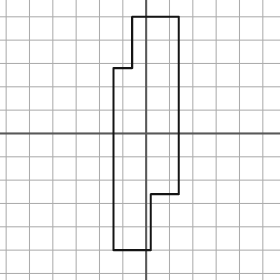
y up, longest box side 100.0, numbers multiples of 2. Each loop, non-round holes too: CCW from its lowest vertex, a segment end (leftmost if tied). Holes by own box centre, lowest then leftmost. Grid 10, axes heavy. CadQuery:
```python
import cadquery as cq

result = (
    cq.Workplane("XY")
    .moveTo(-14.0, -50.0)
    .lineTo(2.0, -50.0)
    .lineTo(2.0, -26.0)
    .lineTo(14.0, -26.0)
    .lineTo(14.0, 50.0)
    .lineTo(-6.0, 50.0)
    .lineTo(-6.0, 28.0)
    .lineTo(-14.0, 28.0)
    .close()
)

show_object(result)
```